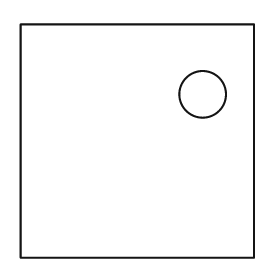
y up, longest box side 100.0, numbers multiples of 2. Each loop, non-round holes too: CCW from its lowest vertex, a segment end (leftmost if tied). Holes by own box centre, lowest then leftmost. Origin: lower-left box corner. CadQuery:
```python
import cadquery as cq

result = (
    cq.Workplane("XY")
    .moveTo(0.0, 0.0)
    .lineTo(100.0, 0.0)
    .lineTo(100.0, 100.0)
    .lineTo(0.0, 100.0)
    .close()
    .moveTo(78.0, 70.0)
    .circle(10.0)
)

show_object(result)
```